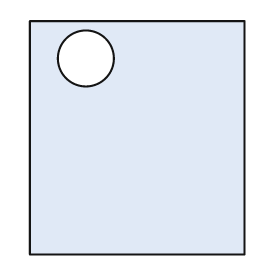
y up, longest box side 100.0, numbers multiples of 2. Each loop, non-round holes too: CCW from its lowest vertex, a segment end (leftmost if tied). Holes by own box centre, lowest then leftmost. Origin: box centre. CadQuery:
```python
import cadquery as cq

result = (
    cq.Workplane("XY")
    .moveTo(-46.0, -50.0)
    .lineTo(46.0, -50.0)
    .lineTo(46.0, 50.0)
    .lineTo(-46.0, 50.0)
    .close()
    .moveTo(-22.0, 34.0)
    .circle(12.0)
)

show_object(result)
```